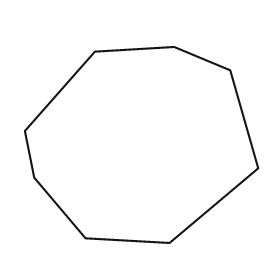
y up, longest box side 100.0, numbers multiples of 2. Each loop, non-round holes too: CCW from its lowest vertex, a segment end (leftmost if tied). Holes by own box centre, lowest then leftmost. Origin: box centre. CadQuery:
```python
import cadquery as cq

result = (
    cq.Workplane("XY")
    .moveTo(12.0, -42.0)
    .lineTo(50.0, -10.0)
    .lineTo(38.0, 32.0)
    .lineTo(14.0, 42.0)
    .lineTo(-20.0, 40.0)
    .lineTo(-50.0, 6.0)
    .lineTo(-46.0, -14.0)
    .lineTo(-24.0, -40.0)
    .close()
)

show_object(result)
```